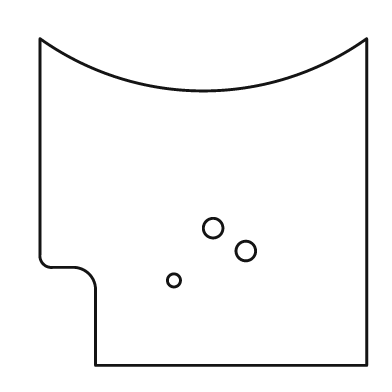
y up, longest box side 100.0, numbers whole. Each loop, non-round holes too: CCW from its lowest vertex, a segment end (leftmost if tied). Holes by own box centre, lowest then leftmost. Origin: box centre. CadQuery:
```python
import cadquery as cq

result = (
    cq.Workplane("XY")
    .moveTo(-33.0, -50.0)
    .lineTo(50.0, -50.0)
    .lineTo(50.0, 50.0)
    .threePointArc((0.0, 34.0), (-50.0, 50.0))
    .lineTo(-50.0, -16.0)
    .threePointArc((-49.0, -19.0), (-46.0, -20.0))
    .lineTo(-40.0, -20.0)
    .threePointArc((-35.0, -22.0), (-33.0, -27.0))
    .close()
    .moveTo(-9.0, -24.0)
    .circle(2.0)
    .moveTo(13.0, -15.0)
    .circle(3.0)
    .moveTo(3.0, -8.0)
    .circle(3.0)
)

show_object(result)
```